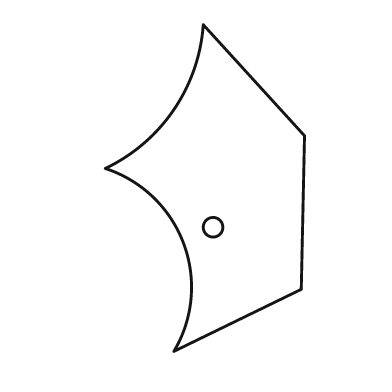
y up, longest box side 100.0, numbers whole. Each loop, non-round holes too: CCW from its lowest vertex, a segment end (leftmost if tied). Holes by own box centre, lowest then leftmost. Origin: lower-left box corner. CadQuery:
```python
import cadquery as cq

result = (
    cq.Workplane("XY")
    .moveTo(21.0, 0.0)
    .lineTo(60.0, 19.0)
    .lineTo(61.0, 66.0)
    .lineTo(30.0, 100.0)
    .threePointArc((21.0, 74.0), (0.0, 56.0))
    .threePointArc((24.0, 33.0), (21.0, 0.0))
    .close()
    .moveTo(33.0, 38.0)
    .circle(3.0)
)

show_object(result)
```